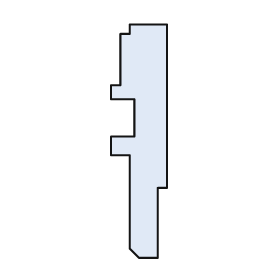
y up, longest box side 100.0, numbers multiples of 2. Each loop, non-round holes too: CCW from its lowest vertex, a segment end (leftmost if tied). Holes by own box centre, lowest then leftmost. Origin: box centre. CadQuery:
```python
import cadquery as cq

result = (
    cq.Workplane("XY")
    .moveTo(0.0, -50.0)
    .lineTo(8.0, -50.0)
    .lineTo(8.0, -20.0)
    .lineTo(12.0, -20.0)
    .lineTo(12.0, 50.0)
    .lineTo(-4.0, 50.0)
    .lineTo(-4.0, 46.0)
    .lineTo(-8.0, 46.0)
    .lineTo(-8.0, 24.0)
    .lineTo(-12.0, 24.0)
    .lineTo(-12.0, 18.0)
    .lineTo(-2.0, 18.0)
    .lineTo(-2.0, 2.0)
    .lineTo(-12.0, 2.0)
    .lineTo(-12.0, -6.0)
    .lineTo(-4.0, -6.0)
    .lineTo(-4.0, -46.0)
    .close()
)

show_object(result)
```